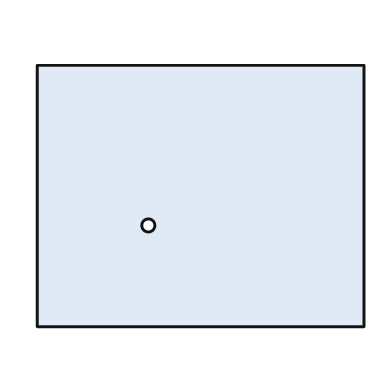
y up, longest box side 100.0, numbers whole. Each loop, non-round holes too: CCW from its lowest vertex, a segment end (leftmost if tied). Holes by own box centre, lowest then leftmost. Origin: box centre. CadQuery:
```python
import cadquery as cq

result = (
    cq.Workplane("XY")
    .moveTo(-50.0, -40.0)
    .lineTo(50.0, -40.0)
    .lineTo(50.0, 40.0)
    .lineTo(-50.0, 40.0)
    .close()
    .moveTo(-16.0, -9.0)
    .circle(2.0)
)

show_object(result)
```